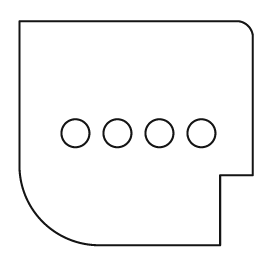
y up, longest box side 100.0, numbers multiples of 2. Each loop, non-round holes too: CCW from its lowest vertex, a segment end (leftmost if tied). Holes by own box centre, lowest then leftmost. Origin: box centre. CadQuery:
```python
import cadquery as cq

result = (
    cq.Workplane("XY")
    .moveTo(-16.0, -48.0)
    .lineTo(36.0, -48.0)
    .lineTo(36.0, -18.0)
    .lineTo(50.0, -18.0)
    .lineTo(50.0, 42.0)
    .threePointArc((48.0, 46.0), (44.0, 48.0))
    .lineTo(-50.0, 48.0)
    .lineTo(-50.0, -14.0)
    .threePointArc((-40.0, -38.0), (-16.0, -48.0))
    .close()
    .moveTo(-26.0, 0.0)
    .circle(6.0)
    .moveTo(-8.0, 0.0)
    .circle(6.0)
    .moveTo(10.0, 0.0)
    .circle(6.0)
    .moveTo(28.0, 0.0)
    .circle(6.0)
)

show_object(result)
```